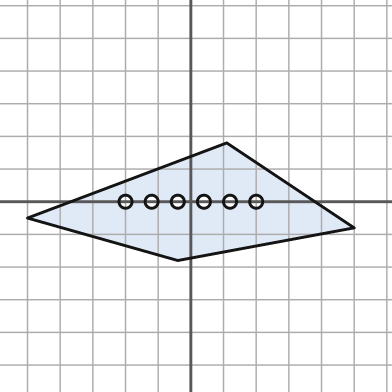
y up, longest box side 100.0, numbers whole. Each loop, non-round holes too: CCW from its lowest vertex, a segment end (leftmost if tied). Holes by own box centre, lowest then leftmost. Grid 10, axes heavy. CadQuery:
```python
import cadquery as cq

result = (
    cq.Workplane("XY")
    .moveTo(-4.0, -18.0)
    .lineTo(50.0, -8.0)
    .lineTo(11.0, 18.0)
    .lineTo(-50.0, -5.0)
    .close()
    .moveTo(-20.0, 0.0)
    .circle(2.0)
    .moveTo(-12.0, 0.0)
    .circle(2.0)
    .moveTo(-4.0, 0.0)
    .circle(2.0)
    .moveTo(4.0, 0.0)
    .circle(2.0)
    .moveTo(12.0, 0.0)
    .circle(2.0)
    .moveTo(20.0, 0.0)
    .circle(2.0)
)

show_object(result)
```